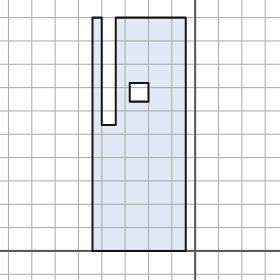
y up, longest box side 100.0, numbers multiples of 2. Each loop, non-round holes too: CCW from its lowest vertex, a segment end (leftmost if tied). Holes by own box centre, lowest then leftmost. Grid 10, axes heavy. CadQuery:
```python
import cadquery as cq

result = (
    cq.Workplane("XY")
    .moveTo(-44.0, 0.0)
    .lineTo(-4.0, 0.0)
    .lineTo(-4.0, 100.0)
    .lineTo(-34.0, 100.0)
    .lineTo(-34.0, 54.0)
    .lineTo(-40.0, 54.0)
    .lineTo(-40.0, 100.0)
    .lineTo(-44.0, 100.0)
    .close()
    .moveTo(-28.0, 64.0)
    .lineTo(-20.0, 64.0)
    .lineTo(-20.0, 72.0)
    .lineTo(-28.0, 72.0)
    .close()
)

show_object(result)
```